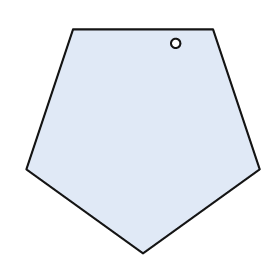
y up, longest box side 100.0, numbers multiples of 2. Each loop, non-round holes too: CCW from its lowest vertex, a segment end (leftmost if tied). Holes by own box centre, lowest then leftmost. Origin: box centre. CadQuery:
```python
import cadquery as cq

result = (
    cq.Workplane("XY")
    .moveTo(0.0, -48.0)
    .lineTo(50.0, -12.0)
    .lineTo(30.0, 48.0)
    .lineTo(-30.0, 48.0)
    .lineTo(-50.0, -12.0)
    .close()
    .moveTo(14.0, 42.0)
    .circle(2.0)
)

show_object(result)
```